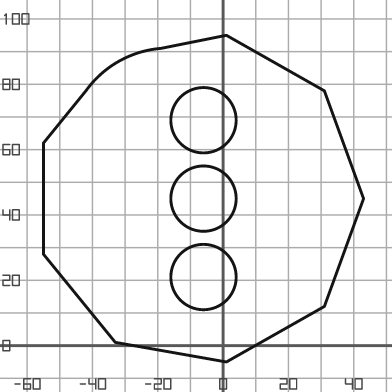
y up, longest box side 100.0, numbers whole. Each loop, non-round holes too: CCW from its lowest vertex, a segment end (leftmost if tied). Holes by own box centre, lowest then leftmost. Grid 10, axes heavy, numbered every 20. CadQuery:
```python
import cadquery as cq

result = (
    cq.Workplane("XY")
    .moveTo(1.0, -5.0)
    .lineTo(31.0, 12.0)
    .lineTo(43.0, 45.0)
    .lineTo(31.0, 78.0)
    .lineTo(1.0, 95.0)
    .lineTo(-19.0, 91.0)
    .threePointArc((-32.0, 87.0), (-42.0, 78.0))
    .lineTo(-55.0, 62.0)
    .lineTo(-55.0, 28.0)
    .lineTo(-33.0, 1.0)
    .close()
    .moveTo(-6.0, 21.0)
    .circle(10.0)
    .moveTo(-6.0, 45.0)
    .circle(10.0)
    .moveTo(-6.0, 69.0)
    .circle(10.0)
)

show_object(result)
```